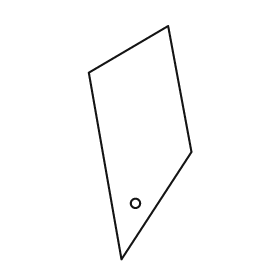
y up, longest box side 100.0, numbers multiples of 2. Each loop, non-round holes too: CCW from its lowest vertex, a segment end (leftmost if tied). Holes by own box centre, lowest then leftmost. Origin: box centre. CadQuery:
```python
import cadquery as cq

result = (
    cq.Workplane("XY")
    .moveTo(-8.0, -50.0)
    .lineTo(22.0, -4.0)
    .lineTo(12.0, 50.0)
    .lineTo(-22.0, 30.0)
    .close()
    .moveTo(-2.0, -26.0)
    .circle(2.0)
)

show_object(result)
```